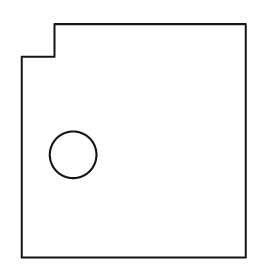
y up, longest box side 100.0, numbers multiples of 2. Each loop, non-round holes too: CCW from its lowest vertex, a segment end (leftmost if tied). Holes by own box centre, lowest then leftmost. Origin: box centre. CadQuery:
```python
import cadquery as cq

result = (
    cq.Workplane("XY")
    .moveTo(-48.0, -50.0)
    .lineTo(48.0, -50.0)
    .lineTo(48.0, 50.0)
    .lineTo(-34.0, 50.0)
    .lineTo(-34.0, 36.0)
    .lineTo(-48.0, 36.0)
    .close()
    .moveTo(-26.0, -6.0)
    .circle(10.0)
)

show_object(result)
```